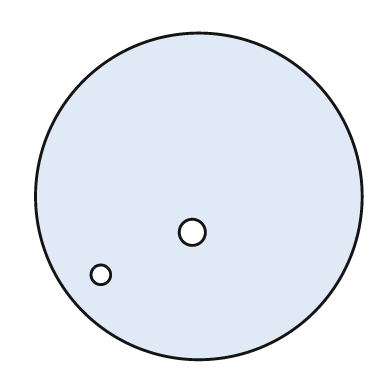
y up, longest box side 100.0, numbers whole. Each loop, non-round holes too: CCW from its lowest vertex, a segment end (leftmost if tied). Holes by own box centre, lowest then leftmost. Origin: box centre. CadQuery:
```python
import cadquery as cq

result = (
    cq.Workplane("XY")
    .moveTo(0.0, 0.0)
    .circle(50.0)
    .moveTo(-30.0, -24.0)
    .circle(3.0)
    .moveTo(-2.0, -11.0)
    .circle(4.0)
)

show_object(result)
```